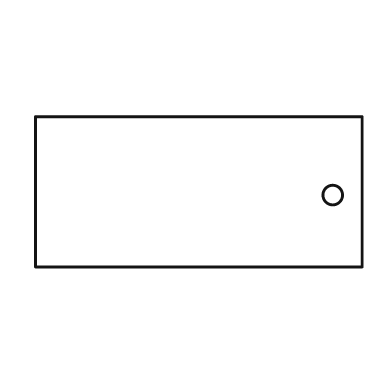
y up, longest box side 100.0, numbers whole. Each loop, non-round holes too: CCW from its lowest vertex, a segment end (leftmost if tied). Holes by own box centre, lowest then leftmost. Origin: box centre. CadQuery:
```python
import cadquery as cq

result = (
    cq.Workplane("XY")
    .moveTo(-50.0, -23.0)
    .lineTo(50.0, -23.0)
    .lineTo(50.0, 23.0)
    .lineTo(-50.0, 23.0)
    .close()
    .moveTo(41.0, -1.0)
    .circle(3.0)
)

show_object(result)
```